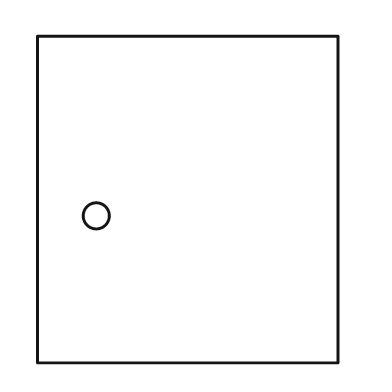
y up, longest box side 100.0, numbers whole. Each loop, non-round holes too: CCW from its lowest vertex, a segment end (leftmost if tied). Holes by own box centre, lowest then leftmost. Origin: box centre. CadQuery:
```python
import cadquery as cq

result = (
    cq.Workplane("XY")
    .moveTo(-46.0, -50.0)
    .lineTo(46.0, -50.0)
    .lineTo(46.0, 50.0)
    .lineTo(-46.0, 50.0)
    .close()
    .moveTo(-28.0, -5.0)
    .circle(4.0)
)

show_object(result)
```